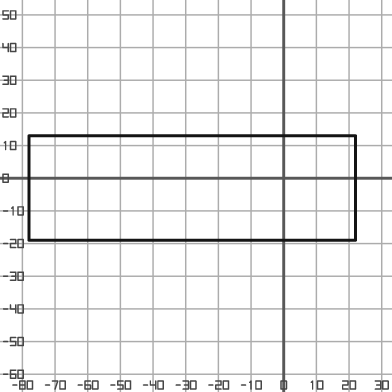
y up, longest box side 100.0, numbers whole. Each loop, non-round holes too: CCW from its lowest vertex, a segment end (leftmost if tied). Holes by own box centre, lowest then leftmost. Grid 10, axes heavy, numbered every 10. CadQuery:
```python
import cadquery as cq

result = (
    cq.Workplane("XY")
    .moveTo(-78.0, -19.0)
    .lineTo(22.0, -19.0)
    .lineTo(22.0, 13.0)
    .lineTo(-78.0, 13.0)
    .close()
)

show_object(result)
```